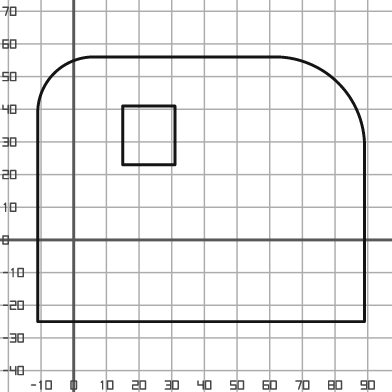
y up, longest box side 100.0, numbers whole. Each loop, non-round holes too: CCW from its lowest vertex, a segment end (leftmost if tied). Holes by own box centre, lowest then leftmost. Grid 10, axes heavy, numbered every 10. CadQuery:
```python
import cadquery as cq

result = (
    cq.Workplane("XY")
    .moveTo(-11.0, -25.0)
    .lineTo(89.0, -25.0)
    .lineTo(89.0, 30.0)
    .threePointArc((81.0, 48.0), (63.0, 56.0))
    .lineTo(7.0, 56.0)
    .threePointArc((-6.0, 51.0), (-11.0, 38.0))
    .close()
    .moveTo(15.0, 23.0)
    .lineTo(31.0, 23.0)
    .lineTo(31.0, 41.0)
    .lineTo(15.0, 41.0)
    .close()
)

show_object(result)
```